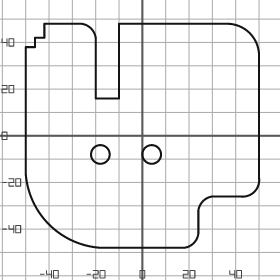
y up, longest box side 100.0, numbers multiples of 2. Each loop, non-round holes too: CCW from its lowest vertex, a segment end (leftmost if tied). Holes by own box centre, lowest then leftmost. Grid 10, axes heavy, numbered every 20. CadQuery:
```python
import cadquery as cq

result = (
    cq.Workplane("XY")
    .moveTo(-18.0, -48.0)
    .lineTo(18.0, -48.0)
    .threePointArc((22.0, -46.0), (24.0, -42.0))
    .lineTo(24.0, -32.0)
    .threePointArc((26.0, -28.0), (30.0, -26.0))
    .lineTo(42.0, -26.0)
    .threePointArc((48.0, -24.0), (50.0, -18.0))
    .lineTo(50.0, 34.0)
    .threePointArc((46.0, 44.0), (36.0, 48.0))
    .lineTo(-10.0, 48.0)
    .lineTo(-10.0, 16.0)
    .lineTo(-20.0, 16.0)
    .lineTo(-20.0, 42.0)
    .threePointArc((-22.0, 46.0), (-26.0, 48.0))
    .lineTo(-42.0, 48.0)
    .lineTo(-42.0, 42.0)
    .lineTo(-46.0, 42.0)
    .lineTo(-46.0, 38.0)
    .lineTo(-50.0, 38.0)
    .lineTo(-50.0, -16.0)
    .threePointArc((-40.0, -38.0), (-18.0, -48.0))
    .close()
    .moveTo(-18.0, -8.0)
    .circle(4.0)
    .moveTo(4.0, -8.0)
    .circle(4.0)
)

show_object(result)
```